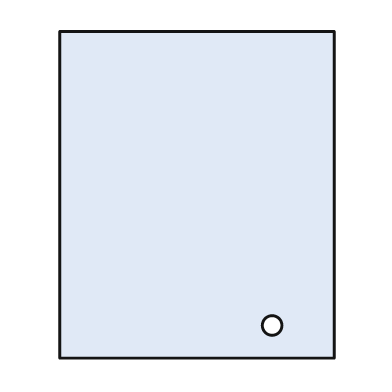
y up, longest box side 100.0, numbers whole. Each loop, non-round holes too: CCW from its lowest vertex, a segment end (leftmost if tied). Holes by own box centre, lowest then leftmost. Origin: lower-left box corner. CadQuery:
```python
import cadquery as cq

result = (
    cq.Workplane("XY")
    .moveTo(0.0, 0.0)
    .lineTo(84.0, 0.0)
    .lineTo(84.0, 100.0)
    .lineTo(0.0, 100.0)
    .close()
    .moveTo(65.0, 10.0)
    .circle(3.0)
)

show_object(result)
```